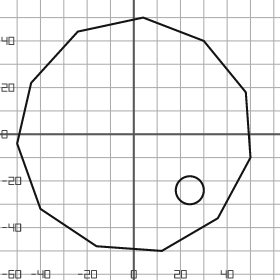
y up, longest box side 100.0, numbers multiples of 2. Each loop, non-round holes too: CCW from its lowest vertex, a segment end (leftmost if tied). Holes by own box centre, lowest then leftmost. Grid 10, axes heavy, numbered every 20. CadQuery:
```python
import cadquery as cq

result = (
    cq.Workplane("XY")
    .moveTo(12.0, -50.0)
    .lineTo(36.0, -36.0)
    .lineTo(50.0, -10.0)
    .lineTo(48.0, 18.0)
    .lineTo(30.0, 40.0)
    .lineTo(4.0, 50.0)
    .lineTo(-24.0, 44.0)
    .lineTo(-44.0, 22.0)
    .lineTo(-50.0, -4.0)
    .lineTo(-40.0, -32.0)
    .lineTo(-16.0, -48.0)
    .close()
    .moveTo(24.0, -24.0)
    .circle(6.0)
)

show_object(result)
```